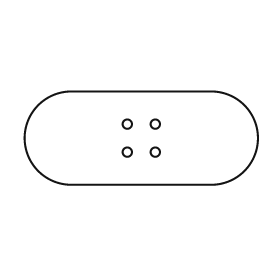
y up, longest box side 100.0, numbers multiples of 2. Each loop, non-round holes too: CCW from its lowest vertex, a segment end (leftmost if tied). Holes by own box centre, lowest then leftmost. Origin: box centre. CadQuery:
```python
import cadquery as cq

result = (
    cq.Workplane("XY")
    .moveTo(-30.0, -20.0)
    .lineTo(30.0, -20.0)
    .threePointArc((50.0, 0.0), (30.0, 20.0))
    .lineTo(-30.0, 20.0)
    .threePointArc((-50.0, 0.0), (-30.0, -20.0))
    .close()
    .moveTo(-6.0, -6.0)
    .circle(2.0)
    .moveTo(6.0, -6.0)
    .circle(2.0)
    .moveTo(-6.0, 6.0)
    .circle(2.0)
    .moveTo(6.0, 6.0)
    .circle(2.0)
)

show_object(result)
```